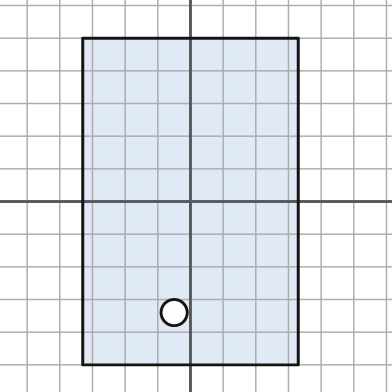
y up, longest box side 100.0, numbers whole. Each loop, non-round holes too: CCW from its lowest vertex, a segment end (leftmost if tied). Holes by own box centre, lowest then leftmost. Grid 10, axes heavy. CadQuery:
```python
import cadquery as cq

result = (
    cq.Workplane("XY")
    .moveTo(-33.0, -50.0)
    .lineTo(33.0, -50.0)
    .lineTo(33.0, 50.0)
    .lineTo(-33.0, 50.0)
    .close()
    .moveTo(-5.0, -34.0)
    .circle(4.0)
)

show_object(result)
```